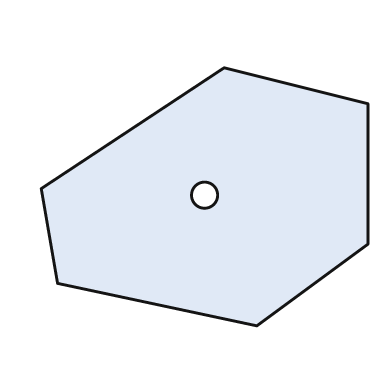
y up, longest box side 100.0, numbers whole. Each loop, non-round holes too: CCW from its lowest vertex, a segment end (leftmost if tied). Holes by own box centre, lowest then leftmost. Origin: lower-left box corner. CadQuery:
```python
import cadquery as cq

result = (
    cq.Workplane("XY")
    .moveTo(66.0, 0.0)
    .lineTo(100.0, 25.0)
    .lineTo(100.0, 68.0)
    .lineTo(56.0, 79.0)
    .lineTo(0.0, 42.0)
    .lineTo(5.0, 13.0)
    .close()
    .moveTo(50.0, 40.0)
    .circle(4.0)
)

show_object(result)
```